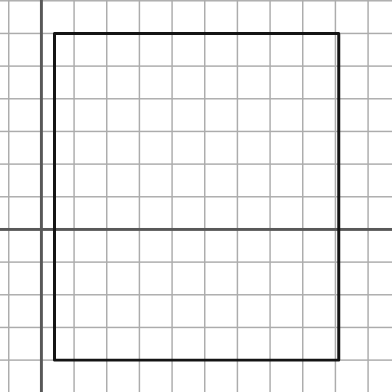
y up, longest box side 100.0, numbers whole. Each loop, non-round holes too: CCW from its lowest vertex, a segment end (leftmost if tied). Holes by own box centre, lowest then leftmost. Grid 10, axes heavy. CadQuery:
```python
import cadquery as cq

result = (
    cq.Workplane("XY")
    .moveTo(4.0, -40.0)
    .lineTo(91.0, -40.0)
    .lineTo(91.0, 60.0)
    .lineTo(4.0, 60.0)
    .close()
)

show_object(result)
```